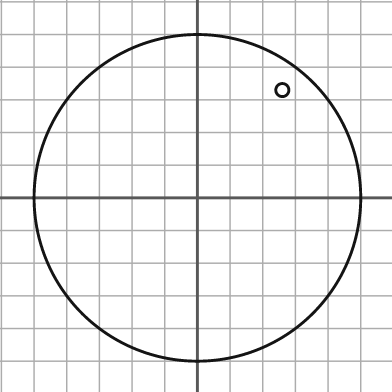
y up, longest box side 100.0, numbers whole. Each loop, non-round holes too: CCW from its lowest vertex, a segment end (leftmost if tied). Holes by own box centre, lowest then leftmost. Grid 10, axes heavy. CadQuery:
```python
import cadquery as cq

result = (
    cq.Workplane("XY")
    .moveTo(0.0, 0.0)
    .circle(50.0)
    .moveTo(26.0, 33.0)
    .circle(2.0)
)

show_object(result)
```